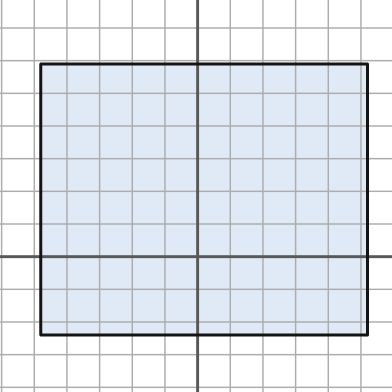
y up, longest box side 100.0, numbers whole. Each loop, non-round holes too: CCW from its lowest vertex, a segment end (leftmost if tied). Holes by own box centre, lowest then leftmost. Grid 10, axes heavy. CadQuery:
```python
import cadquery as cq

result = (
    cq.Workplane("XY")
    .moveTo(-48.0, -24.0)
    .lineTo(52.0, -24.0)
    .lineTo(52.0, 59.0)
    .lineTo(-48.0, 59.0)
    .close()
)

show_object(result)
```